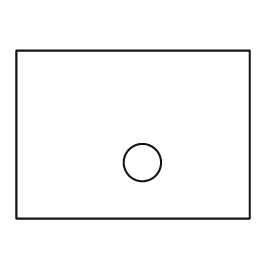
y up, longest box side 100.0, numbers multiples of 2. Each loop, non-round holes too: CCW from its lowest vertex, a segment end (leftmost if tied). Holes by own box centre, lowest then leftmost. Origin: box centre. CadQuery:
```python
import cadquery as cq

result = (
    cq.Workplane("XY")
    .moveTo(-50.0, -36.0)
    .lineTo(50.0, -36.0)
    .lineTo(50.0, 36.0)
    .lineTo(-50.0, 36.0)
    .close()
    .moveTo(4.0, -12.0)
    .circle(8.0)
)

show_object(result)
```